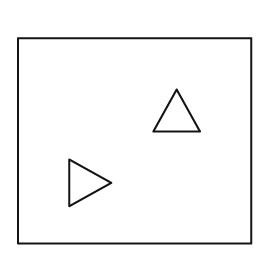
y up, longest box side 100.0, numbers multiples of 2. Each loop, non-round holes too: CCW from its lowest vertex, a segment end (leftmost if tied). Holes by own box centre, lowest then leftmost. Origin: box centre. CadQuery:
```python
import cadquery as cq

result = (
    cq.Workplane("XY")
    .moveTo(-50.0, -44.0)
    .lineTo(50.0, -44.0)
    .lineTo(50.0, 44.0)
    .lineTo(-50.0, 44.0)
    .close()
    .moveTo(-28.0, -28.0)
    .lineTo(-10.0, -18.0)
    .lineTo(-28.0, -8.0)
    .close()
    .moveTo(8.0, 4.0)
    .lineTo(28.0, 4.0)
    .lineTo(18.0, 22.0)
    .close()
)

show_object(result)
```